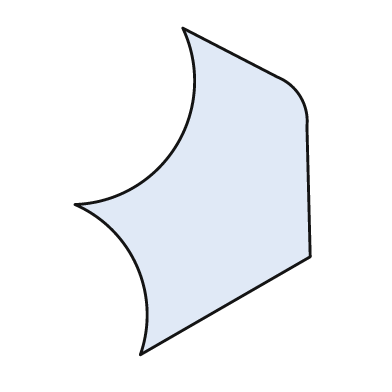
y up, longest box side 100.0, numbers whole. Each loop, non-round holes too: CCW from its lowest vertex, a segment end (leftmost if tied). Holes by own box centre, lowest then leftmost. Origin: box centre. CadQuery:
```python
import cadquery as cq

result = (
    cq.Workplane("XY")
    .moveTo(-16.0, -50.0)
    .lineTo(36.0, -20.0)
    .lineTo(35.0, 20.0)
    .threePointArc((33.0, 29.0), (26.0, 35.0))
    .lineTo(-3.0, 50.0)
    .threePointArc((-5.0, 14.0), (-36.0, -4.0))
    .threePointArc((-17.0, -23.0), (-16.0, -50.0))
    .close()
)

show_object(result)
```